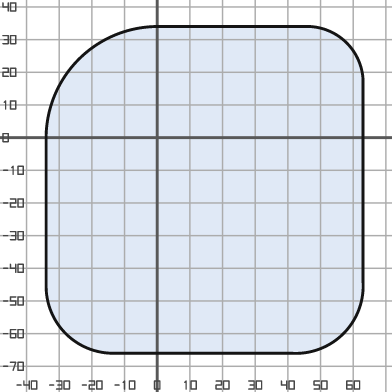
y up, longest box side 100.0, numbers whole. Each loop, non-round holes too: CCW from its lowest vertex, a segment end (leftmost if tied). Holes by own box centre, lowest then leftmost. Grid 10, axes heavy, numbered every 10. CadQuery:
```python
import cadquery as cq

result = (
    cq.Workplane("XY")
    .moveTo(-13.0, -66.0)
    .lineTo(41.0, -66.0)
    .threePointArc((57.0, -60.0), (63.0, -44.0))
    .lineTo(63.0, 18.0)
    .threePointArc((58.0, 29.0), (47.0, 34.0))
    .lineTo(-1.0, 34.0)
    .threePointArc((-24.0, 24.0), (-34.0, 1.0))
    .lineTo(-34.0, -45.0)
    .threePointArc((-28.0, -60.0), (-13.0, -66.0))
    .close()
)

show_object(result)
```